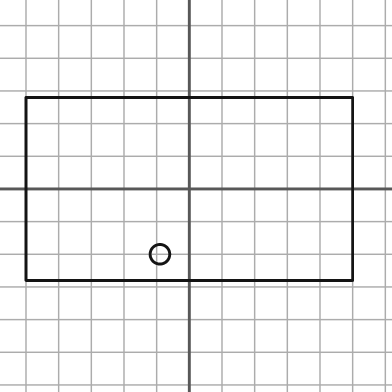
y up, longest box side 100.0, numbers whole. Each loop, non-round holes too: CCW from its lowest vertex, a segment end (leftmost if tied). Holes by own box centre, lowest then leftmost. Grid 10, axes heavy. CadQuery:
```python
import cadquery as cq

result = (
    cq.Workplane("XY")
    .moveTo(-50.0, -28.0)
    .lineTo(50.0, -28.0)
    .lineTo(50.0, 28.0)
    .lineTo(-50.0, 28.0)
    .close()
    .moveTo(-9.0, -20.0)
    .circle(3.0)
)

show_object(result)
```